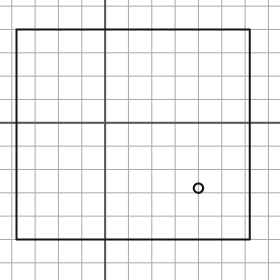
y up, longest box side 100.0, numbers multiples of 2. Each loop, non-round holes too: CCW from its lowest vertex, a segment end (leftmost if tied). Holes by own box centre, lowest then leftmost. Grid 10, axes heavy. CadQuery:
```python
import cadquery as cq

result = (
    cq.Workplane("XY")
    .moveTo(-38.0, -50.0)
    .lineTo(62.0, -50.0)
    .lineTo(62.0, 40.0)
    .lineTo(-38.0, 40.0)
    .close()
    .moveTo(40.0, -28.0)
    .circle(2.0)
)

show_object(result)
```